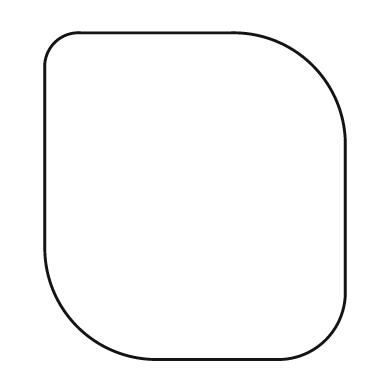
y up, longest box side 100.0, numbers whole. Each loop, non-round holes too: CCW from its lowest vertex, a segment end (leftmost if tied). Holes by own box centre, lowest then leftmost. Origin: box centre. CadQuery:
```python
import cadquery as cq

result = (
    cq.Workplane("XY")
    .moveTo(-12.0, -50.0)
    .lineTo(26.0, -50.0)
    .threePointArc((40.0, -44.0), (46.0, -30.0))
    .lineTo(46.0, 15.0)
    .threePointArc((36.0, 40.0), (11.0, 50.0))
    .lineTo(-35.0, 50.0)
    .threePointArc((-43.0, 47.0), (-46.0, 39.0))
    .lineTo(-46.0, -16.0)
    .threePointArc((-36.0, -40.0), (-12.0, -50.0))
    .close()
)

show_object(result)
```